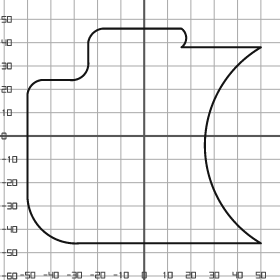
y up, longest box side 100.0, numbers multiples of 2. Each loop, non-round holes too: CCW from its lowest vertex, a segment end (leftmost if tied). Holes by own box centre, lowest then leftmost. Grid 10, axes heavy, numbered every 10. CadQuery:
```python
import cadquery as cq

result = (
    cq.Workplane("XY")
    .moveTo(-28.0, -46.0)
    .lineTo(50.0, -46.0)
    .threePointArc((26.0, -4.0), (50.0, 38.0))
    .lineTo(16.0, 38.0)
    .threePointArc((18.0, 42.0), (16.0, 46.0))
    .lineTo(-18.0, 46.0)
    .threePointArc((-22.0, 44.0), (-24.0, 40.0))
    .lineTo(-24.0, 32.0)
    .threePointArc((-26.0, 26.0), (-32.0, 24.0))
    .lineTo(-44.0, 24.0)
    .threePointArc((-48.0, 22.0), (-50.0, 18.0))
    .lineTo(-50.0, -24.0)
    .threePointArc((-44.0, -40.0), (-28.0, -46.0))
    .close()
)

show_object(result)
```